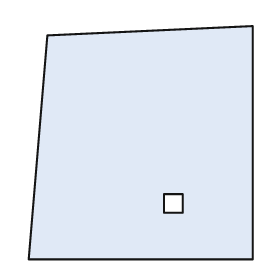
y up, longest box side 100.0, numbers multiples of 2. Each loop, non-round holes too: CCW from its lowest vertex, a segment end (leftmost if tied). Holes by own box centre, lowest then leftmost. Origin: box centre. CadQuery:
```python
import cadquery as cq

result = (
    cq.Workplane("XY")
    .moveTo(-48.0, -50.0)
    .lineTo(48.0, -50.0)
    .lineTo(48.0, 50.0)
    .lineTo(-40.0, 46.0)
    .close()
    .moveTo(10.0, -30.0)
    .lineTo(18.0, -30.0)
    .lineTo(18.0, -22.0)
    .lineTo(10.0, -22.0)
    .close()
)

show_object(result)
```